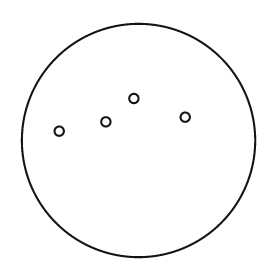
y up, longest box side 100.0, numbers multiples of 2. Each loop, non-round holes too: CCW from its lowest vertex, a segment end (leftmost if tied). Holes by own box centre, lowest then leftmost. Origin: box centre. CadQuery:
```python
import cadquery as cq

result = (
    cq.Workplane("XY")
    .moveTo(0.0, 0.0)
    .circle(50.0)
    .moveTo(-34.0, 4.0)
    .circle(2.0)
    .moveTo(-14.0, 8.0)
    .circle(2.0)
    .moveTo(20.0, 10.0)
    .circle(2.0)
    .moveTo(-2.0, 18.0)
    .circle(2.0)
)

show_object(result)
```